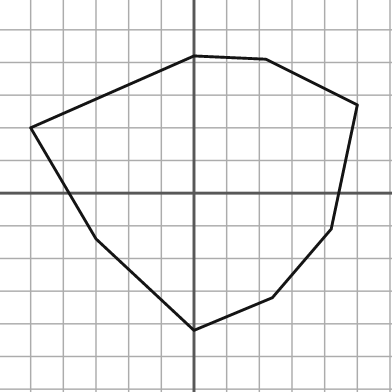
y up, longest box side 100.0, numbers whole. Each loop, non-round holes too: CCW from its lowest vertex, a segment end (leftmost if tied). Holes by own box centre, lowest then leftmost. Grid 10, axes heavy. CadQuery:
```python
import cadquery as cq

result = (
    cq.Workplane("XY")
    .moveTo(0.0, -42.0)
    .lineTo(24.0, -32.0)
    .lineTo(42.0, -11.0)
    .lineTo(50.0, 27.0)
    .lineTo(22.0, 41.0)
    .lineTo(0.0, 42.0)
    .lineTo(-50.0, 20.0)
    .lineTo(-30.0, -14.0)
    .close()
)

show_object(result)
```